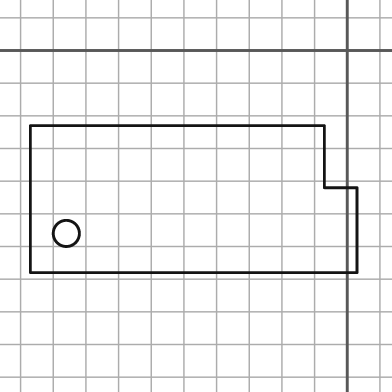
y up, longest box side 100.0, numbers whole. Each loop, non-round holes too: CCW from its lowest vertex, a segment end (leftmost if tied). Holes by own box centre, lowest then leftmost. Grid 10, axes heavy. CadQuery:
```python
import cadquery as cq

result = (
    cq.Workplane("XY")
    .moveTo(-97.0, -68.0)
    .lineTo(3.0, -68.0)
    .lineTo(3.0, -42.0)
    .lineTo(-7.0, -42.0)
    .lineTo(-7.0, -23.0)
    .lineTo(-97.0, -23.0)
    .close()
    .moveTo(-86.0, -56.0)
    .circle(4.0)
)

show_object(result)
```